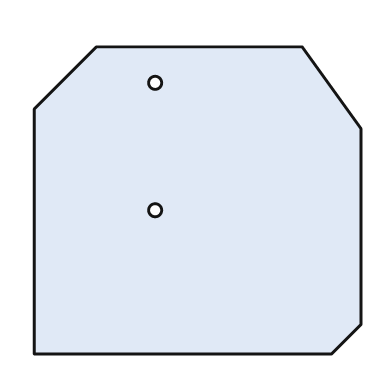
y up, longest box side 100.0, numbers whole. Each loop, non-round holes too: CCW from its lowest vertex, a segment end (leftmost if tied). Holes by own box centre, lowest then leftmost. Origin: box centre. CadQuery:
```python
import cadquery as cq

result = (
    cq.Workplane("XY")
    .moveTo(-50.0, -47.0)
    .lineTo(41.0, -47.0)
    .lineTo(50.0, -38.0)
    .lineTo(50.0, 22.0)
    .lineTo(32.0, 47.0)
    .lineTo(-31.0, 47.0)
    .lineTo(-50.0, 28.0)
    .close()
    .moveTo(-13.0, -3.0)
    .circle(2.0)
    .moveTo(-13.0, 36.0)
    .circle(2.0)
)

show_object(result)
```